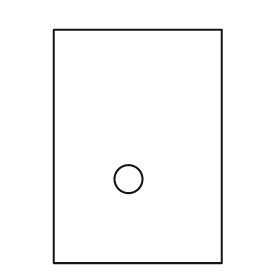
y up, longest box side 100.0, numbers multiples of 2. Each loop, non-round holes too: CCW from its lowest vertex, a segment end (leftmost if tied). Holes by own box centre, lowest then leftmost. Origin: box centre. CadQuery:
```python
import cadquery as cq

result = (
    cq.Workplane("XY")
    .moveTo(-36.0, -50.0)
    .lineTo(36.0, -50.0)
    .lineTo(36.0, 50.0)
    .lineTo(-36.0, 50.0)
    .close()
    .moveTo(-4.0, -14.0)
    .circle(6.0)
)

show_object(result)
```